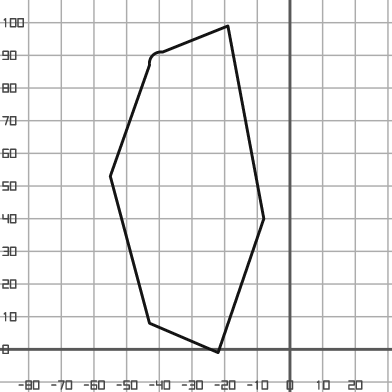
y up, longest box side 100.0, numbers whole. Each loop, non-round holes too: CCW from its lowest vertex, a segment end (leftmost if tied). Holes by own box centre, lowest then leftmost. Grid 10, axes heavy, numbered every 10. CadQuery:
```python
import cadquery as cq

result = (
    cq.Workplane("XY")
    .moveTo(-22.0, -1.0)
    .lineTo(-8.0, 40.0)
    .lineTo(-19.0, 99.0)
    .lineTo(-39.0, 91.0)
    .threePointArc((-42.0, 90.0), (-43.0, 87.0))
    .lineTo(-55.0, 53.0)
    .lineTo(-43.0, 8.0)
    .close()
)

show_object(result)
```